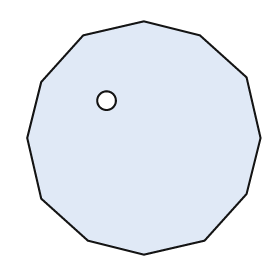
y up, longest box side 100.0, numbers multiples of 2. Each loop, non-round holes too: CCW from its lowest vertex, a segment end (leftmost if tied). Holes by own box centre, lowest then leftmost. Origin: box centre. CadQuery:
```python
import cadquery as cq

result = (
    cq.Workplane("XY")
    .moveTo(0.0, -50.0)
    .lineTo(26.0, -44.0)
    .lineTo(44.0, -24.0)
    .lineTo(50.0, 0.0)
    .lineTo(44.0, 26.0)
    .lineTo(24.0, 44.0)
    .lineTo(0.0, 50.0)
    .lineTo(-26.0, 44.0)
    .lineTo(-44.0, 24.0)
    .lineTo(-50.0, 0.0)
    .lineTo(-44.0, -26.0)
    .lineTo(-24.0, -44.0)
    .close()
    .moveTo(-16.0, 16.0)
    .circle(4.0)
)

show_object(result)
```